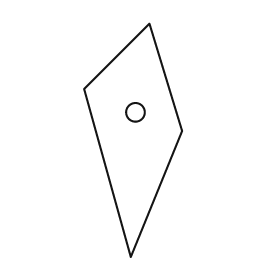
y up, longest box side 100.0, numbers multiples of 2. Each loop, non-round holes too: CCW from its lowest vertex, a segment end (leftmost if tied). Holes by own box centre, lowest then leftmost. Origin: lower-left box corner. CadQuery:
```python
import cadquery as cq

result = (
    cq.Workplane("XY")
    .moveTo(20.0, 0.0)
    .lineTo(42.0, 54.0)
    .lineTo(28.0, 100.0)
    .lineTo(0.0, 72.0)
    .close()
    .moveTo(22.0, 62.0)
    .circle(4.0)
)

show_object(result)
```